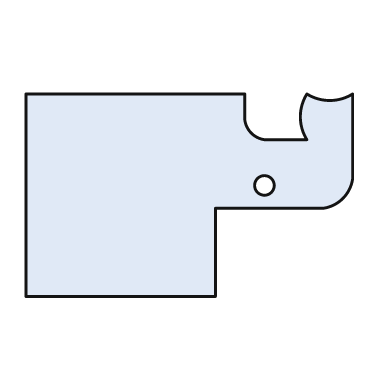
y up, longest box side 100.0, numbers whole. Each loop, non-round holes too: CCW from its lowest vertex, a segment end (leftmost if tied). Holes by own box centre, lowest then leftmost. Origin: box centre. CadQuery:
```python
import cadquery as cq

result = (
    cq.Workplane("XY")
    .moveTo(-50.0, -31.0)
    .lineTo(8.0, -31.0)
    .lineTo(8.0, -4.0)
    .lineTo(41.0, -4.0)
    .threePointArc((47.0, -1.0), (50.0, 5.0))
    .lineTo(50.0, 31.0)
    .threePointArc((43.0, 29.0), (36.0, 31.0))
    .threePointArc((34.0, 24.0), (36.0, 17.0))
    .lineTo(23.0, 17.0)
    .threePointArc((19.0, 19.0), (17.0, 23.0))
    .lineTo(17.0, 31.0)
    .lineTo(-50.0, 31.0)
    .close()
    .moveTo(23.0, 3.0)
    .circle(3.0)
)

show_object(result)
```